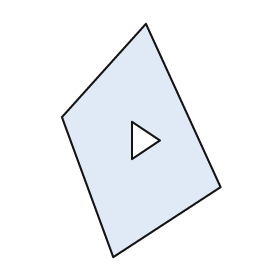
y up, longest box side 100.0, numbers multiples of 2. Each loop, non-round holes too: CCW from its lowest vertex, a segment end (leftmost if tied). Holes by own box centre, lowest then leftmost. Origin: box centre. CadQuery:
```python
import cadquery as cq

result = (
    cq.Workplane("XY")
    .moveTo(-12.0, -50.0)
    .lineTo(34.0, -20.0)
    .lineTo(2.0, 50.0)
    .lineTo(-34.0, 10.0)
    .close()
    .moveTo(-4.0, -8.0)
    .lineTo(8.0, 0.0)
    .lineTo(-4.0, 8.0)
    .close()
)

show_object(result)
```